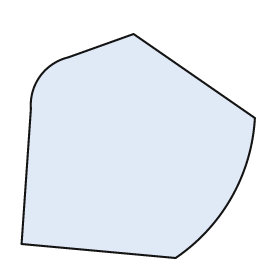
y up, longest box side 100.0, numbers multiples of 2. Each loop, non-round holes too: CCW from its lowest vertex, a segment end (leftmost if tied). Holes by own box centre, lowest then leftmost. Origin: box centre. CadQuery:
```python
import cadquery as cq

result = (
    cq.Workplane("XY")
    .moveTo(16.0, -48.0)
    .threePointArc((40.0, -22.0), (50.0, 12.0))
    .lineTo(-2.0, 48.0)
    .lineTo(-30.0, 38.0)
    .threePointArc((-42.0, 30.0), (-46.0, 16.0))
    .lineTo(-50.0, -42.0)
    .close()
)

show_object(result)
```